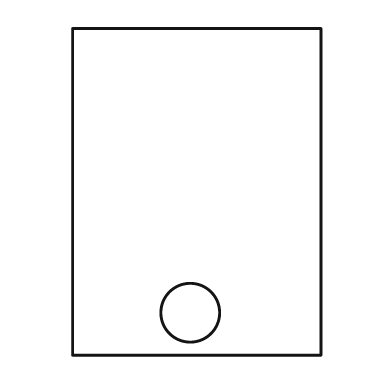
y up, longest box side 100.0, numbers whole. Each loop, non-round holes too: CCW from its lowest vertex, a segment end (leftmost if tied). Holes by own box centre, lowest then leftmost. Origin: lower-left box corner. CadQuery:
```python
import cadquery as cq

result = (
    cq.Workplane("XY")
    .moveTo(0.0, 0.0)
    .lineTo(76.0, 0.0)
    .lineTo(76.0, 100.0)
    .lineTo(0.0, 100.0)
    .close()
    .moveTo(36.0, 13.0)
    .circle(9.0)
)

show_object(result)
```